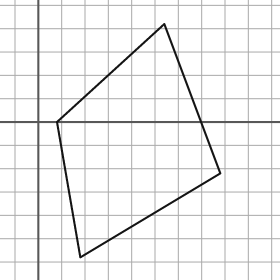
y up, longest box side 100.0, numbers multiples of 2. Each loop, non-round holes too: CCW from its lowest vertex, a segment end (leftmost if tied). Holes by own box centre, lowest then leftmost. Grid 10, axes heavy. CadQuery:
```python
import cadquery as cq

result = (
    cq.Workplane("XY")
    .moveTo(18.0, -58.0)
    .lineTo(78.0, -22.0)
    .lineTo(54.0, 42.0)
    .lineTo(8.0, 0.0)
    .close()
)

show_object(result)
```